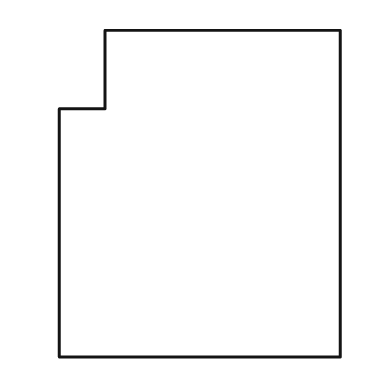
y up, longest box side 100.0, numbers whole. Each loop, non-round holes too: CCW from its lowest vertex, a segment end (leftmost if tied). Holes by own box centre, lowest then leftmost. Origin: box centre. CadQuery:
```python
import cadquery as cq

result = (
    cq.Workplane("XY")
    .moveTo(-43.0, -50.0)
    .lineTo(43.0, -50.0)
    .lineTo(43.0, 50.0)
    .lineTo(-29.0, 50.0)
    .lineTo(-29.0, 26.0)
    .lineTo(-43.0, 26.0)
    .close()
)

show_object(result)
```